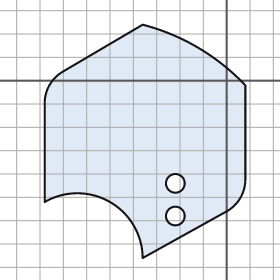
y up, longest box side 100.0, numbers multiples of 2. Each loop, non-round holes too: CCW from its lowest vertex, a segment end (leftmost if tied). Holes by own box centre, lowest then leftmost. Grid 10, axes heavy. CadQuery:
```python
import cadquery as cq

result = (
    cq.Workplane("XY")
    .moveTo(-36.0, -76.0)
    .lineTo(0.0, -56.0)
    .threePointArc((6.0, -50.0), (8.0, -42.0))
    .lineTo(8.0, -2.0)
    .threePointArc((-12.0, 14.0), (-36.0, 24.0))
    .lineTo(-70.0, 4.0)
    .threePointArc((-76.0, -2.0), (-78.0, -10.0))
    .lineTo(-78.0, -52.0)
    .threePointArc((-50.0, -52.0), (-36.0, -76.0))
    .close()
    .moveTo(-22.0, -58.0)
    .circle(4.0)
    .moveTo(-22.0, -44.0)
    .circle(4.0)
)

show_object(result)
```